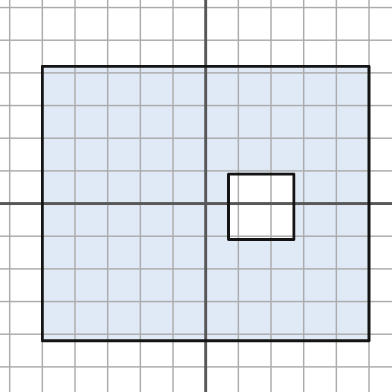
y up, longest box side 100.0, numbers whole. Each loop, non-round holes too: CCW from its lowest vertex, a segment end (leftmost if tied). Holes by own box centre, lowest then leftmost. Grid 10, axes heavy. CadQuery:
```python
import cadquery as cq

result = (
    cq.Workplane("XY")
    .moveTo(-50.0, -42.0)
    .lineTo(50.0, -42.0)
    .lineTo(50.0, 42.0)
    .lineTo(-50.0, 42.0)
    .close()
    .moveTo(7.0, -11.0)
    .lineTo(27.0, -11.0)
    .lineTo(27.0, 9.0)
    .lineTo(7.0, 9.0)
    .close()
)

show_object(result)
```